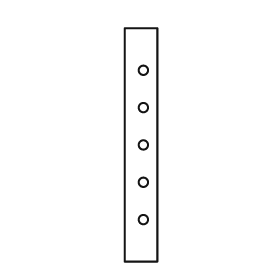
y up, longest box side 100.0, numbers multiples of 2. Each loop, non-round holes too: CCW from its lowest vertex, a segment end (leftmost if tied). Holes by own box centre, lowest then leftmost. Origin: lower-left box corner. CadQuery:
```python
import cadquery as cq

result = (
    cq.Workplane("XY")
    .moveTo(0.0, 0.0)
    .lineTo(14.0, 0.0)
    .lineTo(14.0, 100.0)
    .lineTo(0.0, 100.0)
    .close()
    .moveTo(8.0, 18.0)
    .circle(2.0)
    .moveTo(8.0, 34.0)
    .circle(2.0)
    .moveTo(8.0, 50.0)
    .circle(2.0)
    .moveTo(8.0, 66.0)
    .circle(2.0)
    .moveTo(8.0, 82.0)
    .circle(2.0)
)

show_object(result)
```